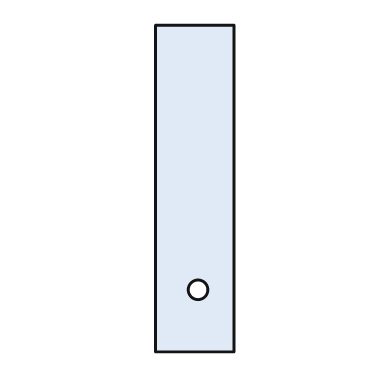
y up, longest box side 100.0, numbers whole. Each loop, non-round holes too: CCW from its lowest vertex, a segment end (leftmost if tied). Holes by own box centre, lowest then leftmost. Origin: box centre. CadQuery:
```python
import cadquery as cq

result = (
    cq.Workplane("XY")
    .moveTo(-12.0, -50.0)
    .lineTo(12.0, -50.0)
    .lineTo(12.0, 50.0)
    .lineTo(-12.0, 50.0)
    .close()
    .moveTo(1.0, -31.0)
    .circle(3.0)
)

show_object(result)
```